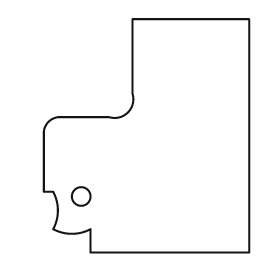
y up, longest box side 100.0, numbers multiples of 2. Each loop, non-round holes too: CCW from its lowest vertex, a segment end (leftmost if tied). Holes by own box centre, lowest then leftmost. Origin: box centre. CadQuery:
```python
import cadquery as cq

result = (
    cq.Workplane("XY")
    .moveTo(-24.0, -50.0)
    .lineTo(44.0, -50.0)
    .lineTo(44.0, 50.0)
    .lineTo(-6.0, 50.0)
    .lineTo(-6.0, 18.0)
    .threePointArc((-8.0, 10.0), (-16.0, 8.0))
    .lineTo(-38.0, 8.0)
    .threePointArc((-42.0, 6.0), (-44.0, 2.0))
    .lineTo(-44.0, -24.0)
    .lineTo(-40.0, -24.0)
    .threePointArc((-38.0, -32.0), (-40.0, -40.0))
    .threePointArc((-32.0, -42.0), (-24.0, -40.0))
    .close()
    .moveTo(-28.0, -26.0)
    .circle(4.0)
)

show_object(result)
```